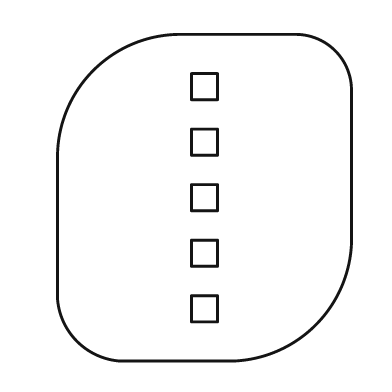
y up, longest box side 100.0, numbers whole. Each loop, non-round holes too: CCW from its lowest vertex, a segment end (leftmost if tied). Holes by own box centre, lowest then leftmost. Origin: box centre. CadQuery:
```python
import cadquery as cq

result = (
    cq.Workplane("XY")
    .moveTo(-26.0, -50.0)
    .lineTo(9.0, -50.0)
    .threePointArc((34.0, -39.0), (45.0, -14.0))
    .lineTo(45.0, 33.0)
    .threePointArc((40.0, 45.0), (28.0, 50.0))
    .lineTo(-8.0, 50.0)
    .threePointArc((-34.0, 39.0), (-45.0, 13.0))
    .lineTo(-45.0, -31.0)
    .threePointArc((-39.0, -44.0), (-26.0, -50.0))
    .close()
    .moveTo(-4.0, -38.0)
    .lineTo(4.0, -38.0)
    .lineTo(4.0, -30.0)
    .lineTo(-4.0, -30.0)
    .close()
    .moveTo(-4.0, -21.0)
    .lineTo(4.0, -21.0)
    .lineTo(4.0, -13.0)
    .lineTo(-4.0, -13.0)
    .close()
    .moveTo(-4.0, -4.0)
    .lineTo(4.0, -4.0)
    .lineTo(4.0, 4.0)
    .lineTo(-4.0, 4.0)
    .close()
    .moveTo(-4.0, 13.0)
    .lineTo(4.0, 13.0)
    .lineTo(4.0, 21.0)
    .lineTo(-4.0, 21.0)
    .close()
    .moveTo(-4.0, 30.0)
    .lineTo(4.0, 30.0)
    .lineTo(4.0, 38.0)
    .lineTo(-4.0, 38.0)
    .close()
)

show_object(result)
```